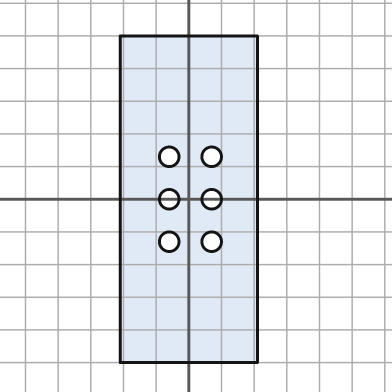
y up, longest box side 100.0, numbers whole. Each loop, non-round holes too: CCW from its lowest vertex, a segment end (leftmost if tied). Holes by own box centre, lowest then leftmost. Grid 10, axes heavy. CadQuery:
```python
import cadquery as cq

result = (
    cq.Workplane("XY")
    .moveTo(-21.0, -50.0)
    .lineTo(21.0, -50.0)
    .lineTo(21.0, 50.0)
    .lineTo(-21.0, 50.0)
    .close()
    .moveTo(-6.0, -13.0)
    .circle(3.0)
    .moveTo(7.0, -13.0)
    .circle(3.0)
    .moveTo(-6.0, 0.0)
    .circle(3.0)
    .moveTo(7.0, 0.0)
    .circle(3.0)
    .moveTo(-6.0, 13.0)
    .circle(3.0)
    .moveTo(7.0, 13.0)
    .circle(3.0)
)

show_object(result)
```